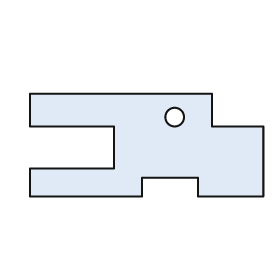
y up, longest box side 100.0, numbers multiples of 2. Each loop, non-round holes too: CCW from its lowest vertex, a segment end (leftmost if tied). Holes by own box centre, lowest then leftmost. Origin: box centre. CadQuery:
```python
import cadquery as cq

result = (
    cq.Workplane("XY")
    .moveTo(-50.0, -22.0)
    .lineTo(-2.0, -22.0)
    .lineTo(-2.0, -14.0)
    .lineTo(22.0, -14.0)
    .lineTo(22.0, -22.0)
    .lineTo(50.0, -22.0)
    .lineTo(50.0, 8.0)
    .lineTo(28.0, 8.0)
    .lineTo(28.0, 22.0)
    .lineTo(-50.0, 22.0)
    .lineTo(-50.0, 8.0)
    .lineTo(-14.0, 8.0)
    .lineTo(-14.0, -10.0)
    .lineTo(-50.0, -10.0)
    .close()
    .moveTo(12.0, 12.0)
    .circle(4.0)
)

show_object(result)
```